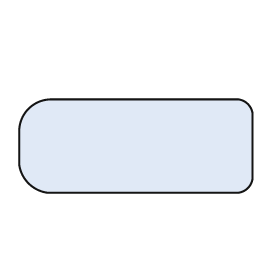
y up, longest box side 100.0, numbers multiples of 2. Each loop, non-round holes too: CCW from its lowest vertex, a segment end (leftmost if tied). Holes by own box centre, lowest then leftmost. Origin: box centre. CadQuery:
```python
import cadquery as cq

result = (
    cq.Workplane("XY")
    .moveTo(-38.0, -20.0)
    .lineTo(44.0, -20.0)
    .threePointArc((48.0, -18.0), (50.0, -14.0))
    .lineTo(50.0, 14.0)
    .threePointArc((48.0, 18.0), (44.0, 20.0))
    .lineTo(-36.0, 20.0)
    .threePointArc((-46.0, 16.0), (-50.0, 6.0))
    .lineTo(-50.0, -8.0)
    .threePointArc((-46.0, -16.0), (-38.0, -20.0))
    .close()
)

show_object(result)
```